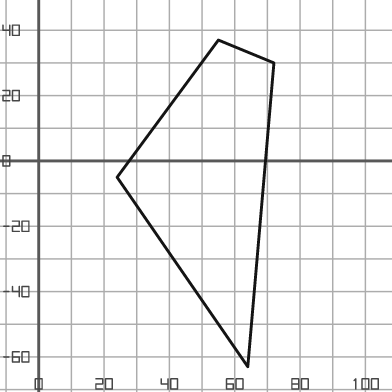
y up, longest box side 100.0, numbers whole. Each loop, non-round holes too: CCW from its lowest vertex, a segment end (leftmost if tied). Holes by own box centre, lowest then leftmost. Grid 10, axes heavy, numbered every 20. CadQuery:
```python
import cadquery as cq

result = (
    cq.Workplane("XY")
    .moveTo(64.0, -63.0)
    .lineTo(72.0, 30.0)
    .lineTo(55.0, 37.0)
    .lineTo(24.0, -5.0)
    .close()
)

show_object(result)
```